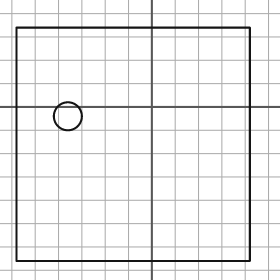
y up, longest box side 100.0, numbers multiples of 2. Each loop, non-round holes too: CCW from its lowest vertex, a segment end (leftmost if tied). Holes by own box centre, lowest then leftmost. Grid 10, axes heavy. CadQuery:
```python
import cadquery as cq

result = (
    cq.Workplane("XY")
    .moveTo(-58.0, -66.0)
    .lineTo(42.0, -66.0)
    .lineTo(42.0, 34.0)
    .lineTo(-58.0, 34.0)
    .close()
    .moveTo(-36.0, -4.0)
    .circle(6.0)
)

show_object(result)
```